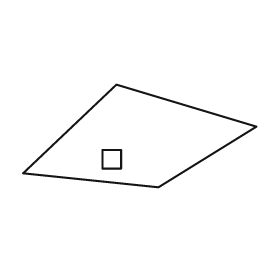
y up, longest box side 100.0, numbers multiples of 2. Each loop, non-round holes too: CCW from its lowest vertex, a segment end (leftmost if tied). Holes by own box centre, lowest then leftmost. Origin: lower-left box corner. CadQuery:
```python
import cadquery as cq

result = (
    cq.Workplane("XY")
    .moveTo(58.0, 0.0)
    .lineTo(100.0, 26.0)
    .lineTo(40.0, 44.0)
    .lineTo(0.0, 6.0)
    .close()
    .moveTo(34.0, 8.0)
    .lineTo(42.0, 8.0)
    .lineTo(42.0, 16.0)
    .lineTo(34.0, 16.0)
    .close()
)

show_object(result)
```